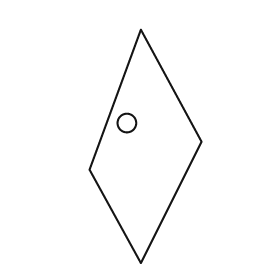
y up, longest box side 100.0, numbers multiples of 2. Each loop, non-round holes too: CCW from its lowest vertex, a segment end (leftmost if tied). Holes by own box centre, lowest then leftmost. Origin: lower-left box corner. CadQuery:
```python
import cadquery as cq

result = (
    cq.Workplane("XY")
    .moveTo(22.0, 0.0)
    .lineTo(48.0, 52.0)
    .lineTo(22.0, 100.0)
    .lineTo(0.0, 40.0)
    .close()
    .moveTo(16.0, 60.0)
    .circle(4.0)
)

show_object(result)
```